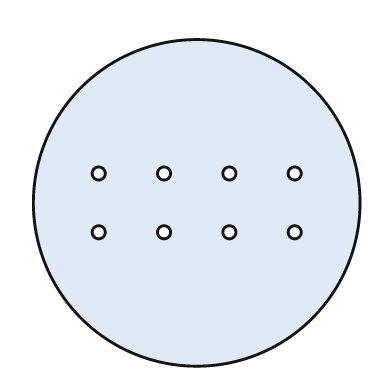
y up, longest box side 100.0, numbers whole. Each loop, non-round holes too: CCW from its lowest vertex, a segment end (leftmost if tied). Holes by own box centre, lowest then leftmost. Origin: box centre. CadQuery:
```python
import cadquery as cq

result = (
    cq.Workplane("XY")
    .moveTo(0.0, 0.0)
    .circle(50.0)
    .moveTo(-30.0, -9.0)
    .circle(2.0)
    .moveTo(-10.0, -9.0)
    .circle(2.0)
    .moveTo(10.0, -9.0)
    .circle(2.0)
    .moveTo(30.0, -9.0)
    .circle(2.0)
    .moveTo(-30.0, 9.0)
    .circle(2.0)
    .moveTo(-10.0, 9.0)
    .circle(2.0)
    .moveTo(10.0, 9.0)
    .circle(2.0)
    .moveTo(30.0, 9.0)
    .circle(2.0)
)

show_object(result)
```